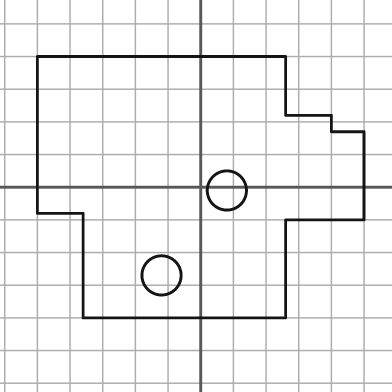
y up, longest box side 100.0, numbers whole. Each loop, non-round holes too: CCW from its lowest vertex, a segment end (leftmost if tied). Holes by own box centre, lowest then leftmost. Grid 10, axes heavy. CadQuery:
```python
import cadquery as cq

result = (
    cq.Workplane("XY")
    .moveTo(-36.0, -40.0)
    .lineTo(26.0, -40.0)
    .lineTo(26.0, -10.0)
    .lineTo(50.0, -10.0)
    .lineTo(50.0, 17.0)
    .lineTo(40.0, 17.0)
    .lineTo(40.0, 22.0)
    .lineTo(26.0, 22.0)
    .lineTo(26.0, 40.0)
    .lineTo(-50.0, 40.0)
    .lineTo(-50.0, -8.0)
    .lineTo(-36.0, -8.0)
    .close()
    .moveTo(-12.0, -27.0)
    .circle(6.0)
    .moveTo(8.0, -1.0)
    .circle(6.0)
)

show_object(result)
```